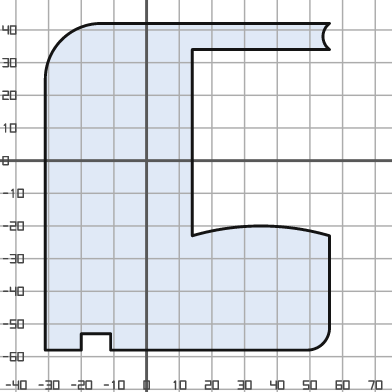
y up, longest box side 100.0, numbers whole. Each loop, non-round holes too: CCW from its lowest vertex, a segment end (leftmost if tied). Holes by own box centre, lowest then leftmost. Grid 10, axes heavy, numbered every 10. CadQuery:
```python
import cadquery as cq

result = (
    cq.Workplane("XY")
    .moveTo(-31.0, -58.0)
    .lineTo(-20.0, -58.0)
    .lineTo(-20.0, -53.0)
    .lineTo(-11.0, -53.0)
    .lineTo(-11.0, -58.0)
    .lineTo(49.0, -58.0)
    .threePointArc((54.0, -56.0), (56.0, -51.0))
    .lineTo(56.0, -23.0)
    .threePointArc((35.0, -20.0), (14.0, -23.0))
    .lineTo(14.0, 34.0)
    .lineTo(56.0, 34.0)
    .threePointArc((54.0, 38.0), (56.0, 42.0))
    .lineTo(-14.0, 42.0)
    .threePointArc((-26.0, 37.0), (-31.0, 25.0))
    .close()
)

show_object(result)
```